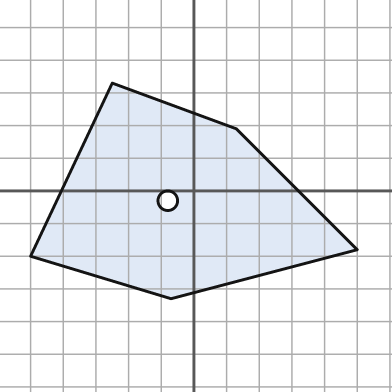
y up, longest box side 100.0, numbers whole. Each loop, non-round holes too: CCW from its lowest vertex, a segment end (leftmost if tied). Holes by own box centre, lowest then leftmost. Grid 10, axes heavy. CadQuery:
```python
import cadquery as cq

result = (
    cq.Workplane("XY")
    .moveTo(-7.0, -33.0)
    .lineTo(50.0, -18.0)
    .lineTo(13.0, 19.0)
    .lineTo(-25.0, 33.0)
    .lineTo(-50.0, -20.0)
    .close()
    .moveTo(-8.0, -3.0)
    .circle(3.0)
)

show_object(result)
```